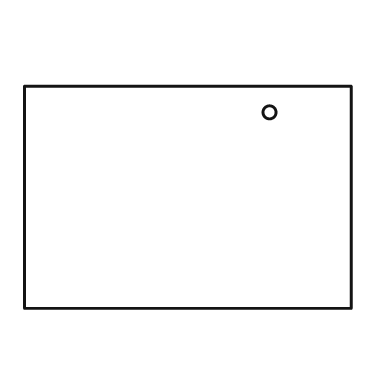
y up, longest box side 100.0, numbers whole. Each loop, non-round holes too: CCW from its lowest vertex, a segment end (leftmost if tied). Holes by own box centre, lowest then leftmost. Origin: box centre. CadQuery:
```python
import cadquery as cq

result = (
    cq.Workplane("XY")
    .moveTo(-50.0, -34.0)
    .lineTo(50.0, -34.0)
    .lineTo(50.0, 34.0)
    .lineTo(-50.0, 34.0)
    .close()
    .moveTo(25.0, 26.0)
    .circle(2.0)
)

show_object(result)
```